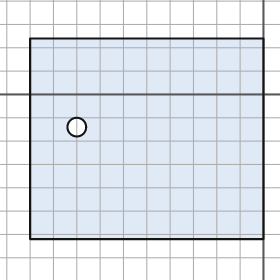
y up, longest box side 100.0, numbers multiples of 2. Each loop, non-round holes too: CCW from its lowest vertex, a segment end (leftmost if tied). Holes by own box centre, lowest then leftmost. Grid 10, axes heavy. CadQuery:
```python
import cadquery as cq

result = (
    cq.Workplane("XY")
    .moveTo(-100.0, -62.0)
    .lineTo(0.0, -62.0)
    .lineTo(0.0, 24.0)
    .lineTo(-100.0, 24.0)
    .close()
    .moveTo(-80.0, -14.0)
    .circle(4.0)
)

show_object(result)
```